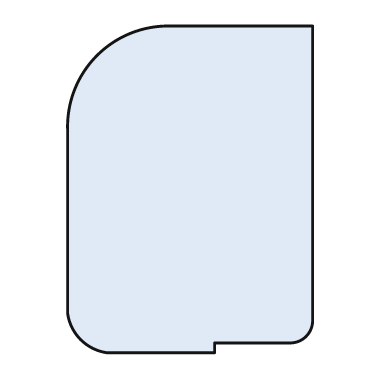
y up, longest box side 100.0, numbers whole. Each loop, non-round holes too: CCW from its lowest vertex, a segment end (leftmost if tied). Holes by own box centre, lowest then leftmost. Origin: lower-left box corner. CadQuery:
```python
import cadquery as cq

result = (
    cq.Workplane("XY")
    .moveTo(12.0, 0.0)
    .lineTo(45.0, 0.0)
    .lineTo(45.0, 3.0)
    .lineTo(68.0, 3.0)
    .threePointArc((73.0, 5.0), (75.0, 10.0))
    .lineTo(75.0, 100.0)
    .lineTo(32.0, 100.0)
    .threePointArc((9.0, 91.0), (0.0, 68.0))
    .lineTo(0.0, 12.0)
    .threePointArc((4.0, 4.0), (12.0, 0.0))
    .close()
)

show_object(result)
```